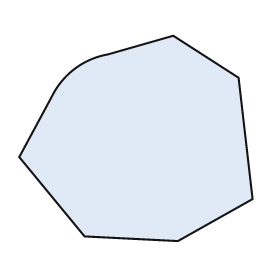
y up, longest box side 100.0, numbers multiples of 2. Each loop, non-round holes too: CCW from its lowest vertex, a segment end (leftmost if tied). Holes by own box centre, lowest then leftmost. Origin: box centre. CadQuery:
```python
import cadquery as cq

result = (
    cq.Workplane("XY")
    .moveTo(18.0, -44.0)
    .lineTo(50.0, -26.0)
    .lineTo(44.0, 26.0)
    .lineTo(16.0, 44.0)
    .lineTo(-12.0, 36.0)
    .threePointArc((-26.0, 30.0), (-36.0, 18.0))
    .lineTo(-50.0, -8.0)
    .lineTo(-22.0, -42.0)
    .close()
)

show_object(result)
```